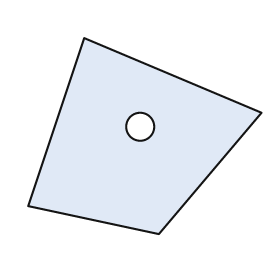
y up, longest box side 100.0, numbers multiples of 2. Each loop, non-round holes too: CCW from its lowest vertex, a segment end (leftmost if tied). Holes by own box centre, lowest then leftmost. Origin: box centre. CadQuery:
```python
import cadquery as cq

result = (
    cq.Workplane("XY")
    .moveTo(6.0, -42.0)
    .lineTo(50.0, 10.0)
    .lineTo(-26.0, 42.0)
    .lineTo(-50.0, -30.0)
    .close()
    .moveTo(-2.0, 4.0)
    .circle(6.0)
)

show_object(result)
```